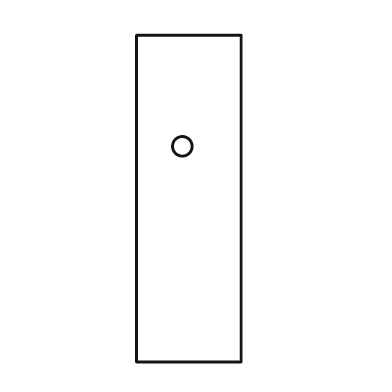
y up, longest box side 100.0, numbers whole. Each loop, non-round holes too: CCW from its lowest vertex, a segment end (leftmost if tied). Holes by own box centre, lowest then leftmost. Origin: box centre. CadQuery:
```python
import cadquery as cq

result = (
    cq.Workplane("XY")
    .moveTo(-16.0, -50.0)
    .lineTo(16.0, -50.0)
    .lineTo(16.0, 50.0)
    .lineTo(-16.0, 50.0)
    .close()
    .moveTo(-2.0, 16.0)
    .circle(3.0)
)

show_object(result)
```